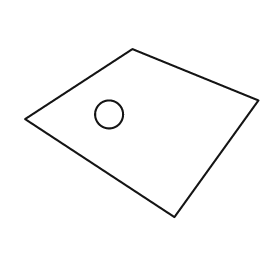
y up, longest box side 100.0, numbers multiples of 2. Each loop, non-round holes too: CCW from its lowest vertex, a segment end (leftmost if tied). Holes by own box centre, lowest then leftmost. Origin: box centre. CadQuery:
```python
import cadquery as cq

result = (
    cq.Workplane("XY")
    .moveTo(14.0, -36.0)
    .lineTo(50.0, 14.0)
    .lineTo(-4.0, 36.0)
    .lineTo(-50.0, 6.0)
    .close()
    .moveTo(-14.0, 8.0)
    .circle(6.0)
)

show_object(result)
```